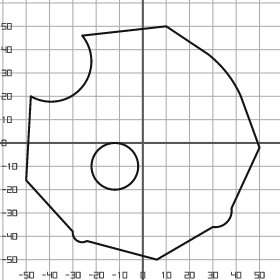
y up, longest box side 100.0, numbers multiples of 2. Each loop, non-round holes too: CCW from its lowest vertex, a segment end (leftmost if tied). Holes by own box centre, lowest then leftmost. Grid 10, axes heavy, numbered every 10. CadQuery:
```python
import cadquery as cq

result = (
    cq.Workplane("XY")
    .moveTo(6.0, -50.0)
    .lineTo(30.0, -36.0)
    .threePointArc((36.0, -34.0), (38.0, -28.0))
    .lineTo(50.0, -2.0)
    .lineTo(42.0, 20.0)
    .threePointArc((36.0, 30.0), (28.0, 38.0))
    .lineTo(10.0, 50.0)
    .lineTo(-26.0, 46.0)
    .threePointArc((-26.0, 24.0), (-48.0, 20.0))
    .lineTo(-50.0, -16.0)
    .lineTo(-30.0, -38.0)
    .threePointArc((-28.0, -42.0), (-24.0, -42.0))
    .close()
    .moveTo(-12.0, -10.0)
    .circle(10.0)
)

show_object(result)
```